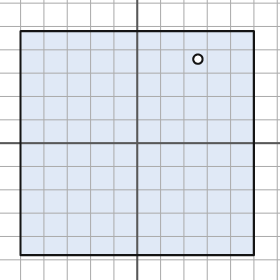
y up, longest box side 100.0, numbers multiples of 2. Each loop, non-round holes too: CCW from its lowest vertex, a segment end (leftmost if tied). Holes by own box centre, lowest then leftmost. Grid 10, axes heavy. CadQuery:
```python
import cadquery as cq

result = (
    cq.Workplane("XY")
    .moveTo(-50.0, -48.0)
    .lineTo(50.0, -48.0)
    .lineTo(50.0, 48.0)
    .lineTo(-50.0, 48.0)
    .close()
    .moveTo(26.0, 36.0)
    .circle(2.0)
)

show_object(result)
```